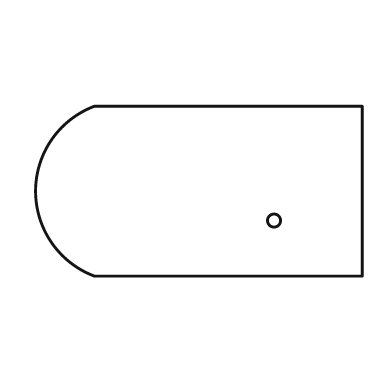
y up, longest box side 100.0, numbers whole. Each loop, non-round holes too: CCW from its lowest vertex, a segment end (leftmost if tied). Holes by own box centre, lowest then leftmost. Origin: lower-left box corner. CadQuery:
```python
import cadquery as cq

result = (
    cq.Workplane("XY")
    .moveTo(18.0, 0.0)
    .lineTo(100.0, 0.0)
    .lineTo(100.0, 52.0)
    .lineTo(18.0, 52.0)
    .threePointArc((0.0, 26.0), (18.0, 0.0))
    .close()
    .moveTo(73.0, 17.0)
    .circle(2.0)
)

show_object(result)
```